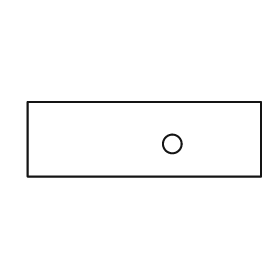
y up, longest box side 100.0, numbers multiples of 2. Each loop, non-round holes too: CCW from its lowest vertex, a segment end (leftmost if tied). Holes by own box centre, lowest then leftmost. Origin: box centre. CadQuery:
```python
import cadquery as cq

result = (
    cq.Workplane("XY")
    .moveTo(-50.0, -16.0)
    .lineTo(50.0, -16.0)
    .lineTo(50.0, 16.0)
    .lineTo(-50.0, 16.0)
    .close()
    .moveTo(12.0, -2.0)
    .circle(4.0)
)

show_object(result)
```